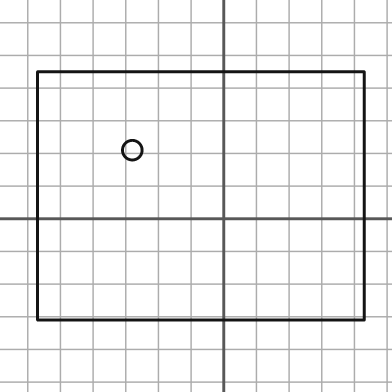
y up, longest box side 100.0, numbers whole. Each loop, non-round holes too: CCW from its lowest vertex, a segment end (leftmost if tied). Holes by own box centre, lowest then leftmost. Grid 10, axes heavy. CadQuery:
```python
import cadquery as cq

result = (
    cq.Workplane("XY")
    .moveTo(-57.0, -31.0)
    .lineTo(43.0, -31.0)
    .lineTo(43.0, 45.0)
    .lineTo(-57.0, 45.0)
    .close()
    .moveTo(-28.0, 21.0)
    .circle(3.0)
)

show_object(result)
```